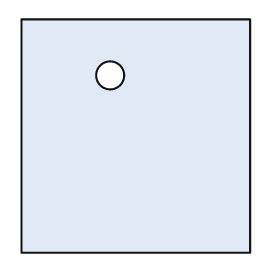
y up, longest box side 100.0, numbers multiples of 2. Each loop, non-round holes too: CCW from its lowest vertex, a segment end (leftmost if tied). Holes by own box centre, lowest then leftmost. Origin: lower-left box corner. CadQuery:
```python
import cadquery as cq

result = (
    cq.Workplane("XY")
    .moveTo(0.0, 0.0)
    .lineTo(98.0, 0.0)
    .lineTo(98.0, 100.0)
    .lineTo(0.0, 100.0)
    .close()
    .moveTo(38.0, 76.0)
    .circle(6.0)
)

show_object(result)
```